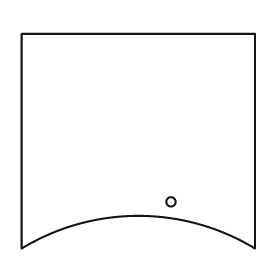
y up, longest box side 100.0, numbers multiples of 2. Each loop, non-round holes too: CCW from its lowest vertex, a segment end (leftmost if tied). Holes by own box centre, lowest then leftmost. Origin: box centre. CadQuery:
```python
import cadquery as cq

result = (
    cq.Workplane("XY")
    .moveTo(-50.0, -46.0)
    .threePointArc((0.0, -32.0), (50.0, -46.0))
    .lineTo(50.0, 46.0)
    .lineTo(-50.0, 46.0)
    .close()
    .moveTo(14.0, -26.0)
    .circle(2.0)
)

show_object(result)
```